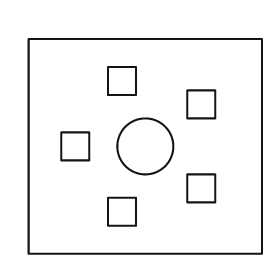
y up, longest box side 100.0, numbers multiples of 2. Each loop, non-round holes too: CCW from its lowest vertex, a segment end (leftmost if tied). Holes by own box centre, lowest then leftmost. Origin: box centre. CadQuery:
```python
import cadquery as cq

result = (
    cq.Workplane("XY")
    .moveTo(-50.0, -46.0)
    .lineTo(50.0, -46.0)
    .lineTo(50.0, 46.0)
    .lineTo(-50.0, 46.0)
    .close()
    .moveTo(-16.0, -34.0)
    .lineTo(-4.0, -34.0)
    .lineTo(-4.0, -22.0)
    .lineTo(-16.0, -22.0)
    .close()
    .moveTo(18.0, -24.0)
    .lineTo(30.0, -24.0)
    .lineTo(30.0, -12.0)
    .lineTo(18.0, -12.0)
    .close()
    .moveTo(-36.0, -6.0)
    .lineTo(-24.0, -6.0)
    .lineTo(-24.0, 6.0)
    .lineTo(-36.0, 6.0)
    .close()
    .moveTo(0.0, 0.0)
    .circle(12.0)
    .moveTo(18.0, 12.0)
    .lineTo(30.0, 12.0)
    .lineTo(30.0, 24.0)
    .lineTo(18.0, 24.0)
    .close()
    .moveTo(-16.0, 22.0)
    .lineTo(-4.0, 22.0)
    .lineTo(-4.0, 34.0)
    .lineTo(-16.0, 34.0)
    .close()
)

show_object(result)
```